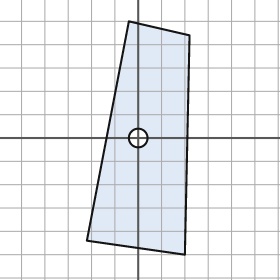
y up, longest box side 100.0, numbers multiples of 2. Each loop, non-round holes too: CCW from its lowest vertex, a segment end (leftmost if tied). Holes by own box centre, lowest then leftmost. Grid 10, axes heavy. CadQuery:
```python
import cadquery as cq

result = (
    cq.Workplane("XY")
    .moveTo(20.0, -50.0)
    .lineTo(22.0, 44.0)
    .lineTo(-4.0, 50.0)
    .lineTo(-22.0, -44.0)
    .close()
    .moveTo(0.0, 0.0)
    .circle(4.0)
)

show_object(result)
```